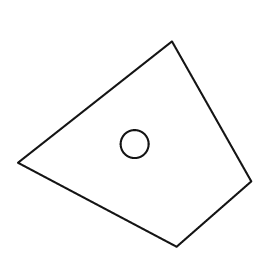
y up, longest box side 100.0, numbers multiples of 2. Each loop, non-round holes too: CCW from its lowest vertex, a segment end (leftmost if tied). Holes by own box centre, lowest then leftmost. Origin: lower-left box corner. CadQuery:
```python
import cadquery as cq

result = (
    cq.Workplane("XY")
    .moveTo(68.0, 0.0)
    .lineTo(100.0, 28.0)
    .lineTo(66.0, 88.0)
    .lineTo(0.0, 36.0)
    .close()
    .moveTo(50.0, 44.0)
    .circle(6.0)
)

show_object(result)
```